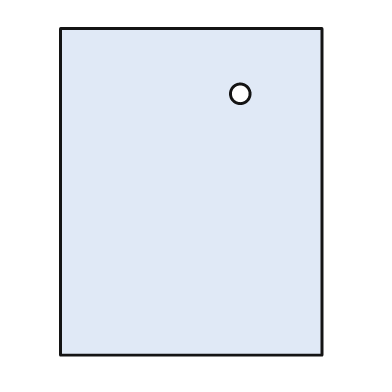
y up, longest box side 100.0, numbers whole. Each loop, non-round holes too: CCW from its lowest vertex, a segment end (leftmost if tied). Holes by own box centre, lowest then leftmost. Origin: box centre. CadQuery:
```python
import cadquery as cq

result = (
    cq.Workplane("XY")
    .moveTo(-40.0, -50.0)
    .lineTo(40.0, -50.0)
    .lineTo(40.0, 50.0)
    .lineTo(-40.0, 50.0)
    .close()
    .moveTo(15.0, 30.0)
    .circle(3.0)
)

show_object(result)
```